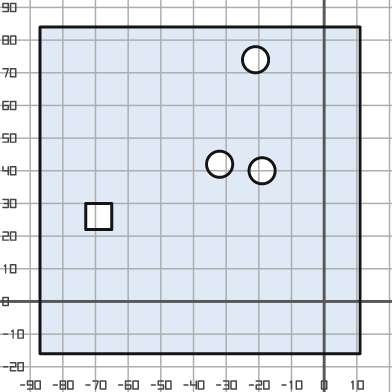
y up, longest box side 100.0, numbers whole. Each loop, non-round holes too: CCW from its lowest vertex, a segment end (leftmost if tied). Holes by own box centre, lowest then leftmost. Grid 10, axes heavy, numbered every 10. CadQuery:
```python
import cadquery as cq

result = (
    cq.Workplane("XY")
    .moveTo(-87.0, -16.0)
    .lineTo(11.0, -16.0)
    .lineTo(11.0, 84.0)
    .lineTo(-87.0, 84.0)
    .close()
    .moveTo(-73.0, 22.0)
    .lineTo(-65.0, 22.0)
    .lineTo(-65.0, 30.0)
    .lineTo(-73.0, 30.0)
    .close()
    .moveTo(-19.0, 40.0)
    .circle(4.0)
    .moveTo(-32.0, 42.0)
    .circle(4.0)
    .moveTo(-21.0, 74.0)
    .circle(4.0)
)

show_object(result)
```